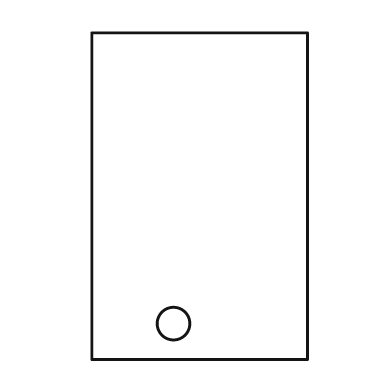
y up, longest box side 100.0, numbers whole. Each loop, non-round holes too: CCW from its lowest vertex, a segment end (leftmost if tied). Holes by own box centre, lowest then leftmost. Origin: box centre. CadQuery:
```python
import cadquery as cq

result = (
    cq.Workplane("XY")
    .moveTo(-33.0, -50.0)
    .lineTo(33.0, -50.0)
    .lineTo(33.0, 50.0)
    .lineTo(-33.0, 50.0)
    .close()
    .moveTo(-8.0, -39.0)
    .circle(5.0)
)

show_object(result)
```